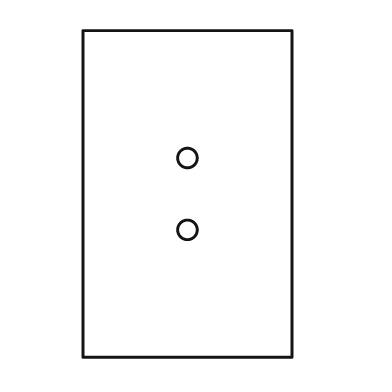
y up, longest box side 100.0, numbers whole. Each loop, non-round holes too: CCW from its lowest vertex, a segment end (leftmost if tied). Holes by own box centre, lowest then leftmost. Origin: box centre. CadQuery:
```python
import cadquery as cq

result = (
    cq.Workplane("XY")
    .moveTo(-32.0, -50.0)
    .lineTo(32.0, -50.0)
    .lineTo(32.0, 50.0)
    .lineTo(-32.0, 50.0)
    .close()
    .moveTo(0.0, -11.0)
    .circle(3.0)
    .moveTo(0.0, 11.0)
    .circle(3.0)
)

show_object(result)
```